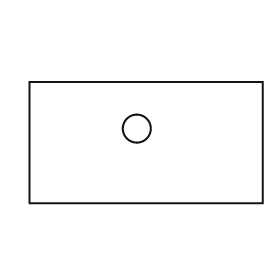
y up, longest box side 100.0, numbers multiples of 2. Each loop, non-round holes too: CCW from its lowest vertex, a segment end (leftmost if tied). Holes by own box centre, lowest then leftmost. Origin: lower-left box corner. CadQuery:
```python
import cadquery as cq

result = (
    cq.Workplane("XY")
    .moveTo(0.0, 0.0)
    .lineTo(100.0, 0.0)
    .lineTo(100.0, 52.0)
    .lineTo(0.0, 52.0)
    .close()
    .moveTo(46.0, 32.0)
    .circle(6.0)
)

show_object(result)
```